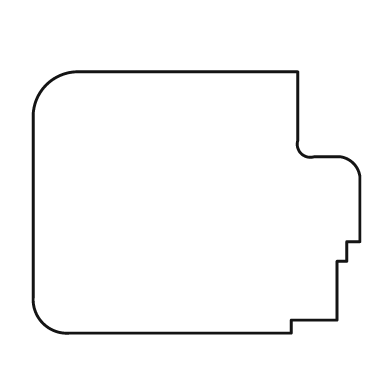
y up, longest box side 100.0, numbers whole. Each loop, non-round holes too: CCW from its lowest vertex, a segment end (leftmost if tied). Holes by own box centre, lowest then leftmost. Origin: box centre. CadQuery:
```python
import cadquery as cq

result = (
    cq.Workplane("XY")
    .moveTo(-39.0, -40.0)
    .lineTo(29.0, -40.0)
    .lineTo(29.0, -36.0)
    .lineTo(43.0, -36.0)
    .lineTo(43.0, -18.0)
    .lineTo(46.0, -18.0)
    .lineTo(46.0, -12.0)
    .lineTo(50.0, -12.0)
    .lineTo(50.0, 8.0)
    .threePointArc((48.0, 12.0), (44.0, 14.0))
    .lineTo(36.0, 14.0)
    .threePointArc((32.0, 15.0), (31.0, 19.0))
    .lineTo(31.0, 40.0)
    .lineTo(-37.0, 40.0)
    .threePointArc((-46.0, 36.0), (-50.0, 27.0))
    .lineTo(-50.0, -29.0)
    .threePointArc((-47.0, -37.0), (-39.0, -40.0))
    .close()
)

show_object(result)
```